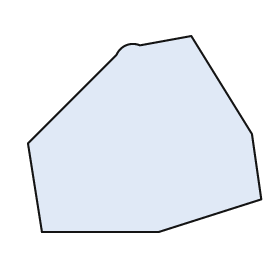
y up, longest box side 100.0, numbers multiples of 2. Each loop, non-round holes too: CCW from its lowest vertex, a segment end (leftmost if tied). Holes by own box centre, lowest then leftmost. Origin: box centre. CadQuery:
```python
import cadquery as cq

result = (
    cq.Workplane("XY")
    .moveTo(-44.0, -42.0)
    .lineTo(6.0, -42.0)
    .lineTo(50.0, -28.0)
    .lineTo(46.0, 0.0)
    .lineTo(20.0, 42.0)
    .lineTo(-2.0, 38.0)
    .threePointArc((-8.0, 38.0), (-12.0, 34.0))
    .lineTo(-50.0, -4.0)
    .close()
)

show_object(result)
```